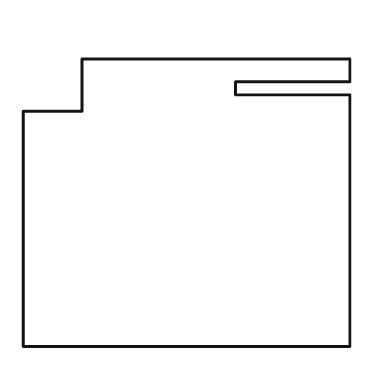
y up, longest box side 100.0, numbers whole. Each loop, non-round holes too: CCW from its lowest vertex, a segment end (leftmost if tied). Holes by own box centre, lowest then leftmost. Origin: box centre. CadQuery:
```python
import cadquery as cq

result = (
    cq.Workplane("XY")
    .moveTo(-50.0, -44.0)
    .lineTo(50.0, -44.0)
    .lineTo(50.0, 33.0)
    .lineTo(15.0, 33.0)
    .lineTo(15.0, 37.0)
    .lineTo(50.0, 37.0)
    .lineTo(50.0, 44.0)
    .lineTo(-32.0, 44.0)
    .lineTo(-32.0, 28.0)
    .lineTo(-50.0, 28.0)
    .close()
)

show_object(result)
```